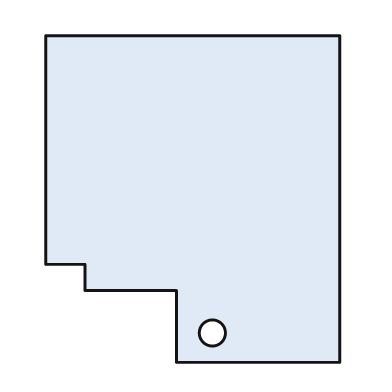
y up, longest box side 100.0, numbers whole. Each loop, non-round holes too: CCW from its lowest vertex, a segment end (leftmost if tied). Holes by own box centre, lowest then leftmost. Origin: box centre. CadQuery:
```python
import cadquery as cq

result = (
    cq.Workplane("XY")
    .moveTo(-5.0, -50.0)
    .lineTo(45.0, -50.0)
    .lineTo(45.0, 50.0)
    .lineTo(-45.0, 50.0)
    .lineTo(-45.0, -20.0)
    .lineTo(-33.0, -20.0)
    .lineTo(-33.0, -28.0)
    .lineTo(-5.0, -28.0)
    .close()
    .moveTo(6.0, -41.0)
    .circle(4.0)
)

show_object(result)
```